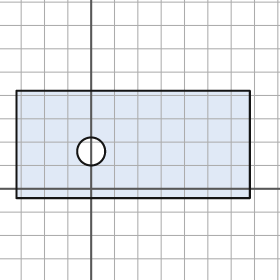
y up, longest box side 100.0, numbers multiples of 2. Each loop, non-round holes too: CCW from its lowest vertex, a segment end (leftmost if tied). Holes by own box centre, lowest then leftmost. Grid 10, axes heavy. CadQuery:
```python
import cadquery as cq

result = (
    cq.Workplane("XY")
    .moveTo(-32.0, -4.0)
    .lineTo(68.0, -4.0)
    .lineTo(68.0, 42.0)
    .lineTo(-32.0, 42.0)
    .close()
    .moveTo(0.0, 16.0)
    .circle(6.0)
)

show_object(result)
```